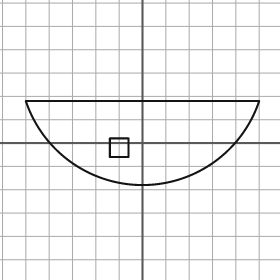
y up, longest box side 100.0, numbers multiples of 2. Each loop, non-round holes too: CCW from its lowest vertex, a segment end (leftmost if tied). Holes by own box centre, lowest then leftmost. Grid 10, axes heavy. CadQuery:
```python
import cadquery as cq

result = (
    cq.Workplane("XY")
    .moveTo(-50.0, 18.0)
    .threePointArc((0.0, -18.0), (50.0, 18.0))
    .close()
    .moveTo(-14.0, -6.0)
    .lineTo(-6.0, -6.0)
    .lineTo(-6.0, 2.0)
    .lineTo(-14.0, 2.0)
    .close()
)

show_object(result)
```